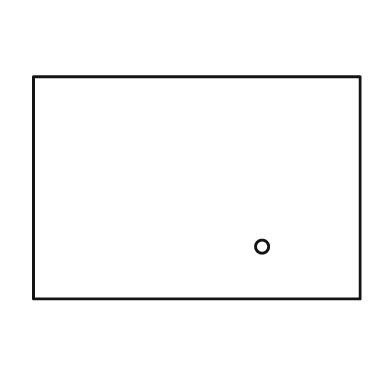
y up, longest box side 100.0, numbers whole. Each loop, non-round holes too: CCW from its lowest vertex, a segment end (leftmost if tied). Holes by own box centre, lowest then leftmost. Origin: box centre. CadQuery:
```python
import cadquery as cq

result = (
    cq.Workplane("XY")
    .moveTo(-50.0, -34.0)
    .lineTo(50.0, -34.0)
    .lineTo(50.0, 34.0)
    .lineTo(-50.0, 34.0)
    .close()
    .moveTo(20.0, -18.0)
    .circle(2.0)
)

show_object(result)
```